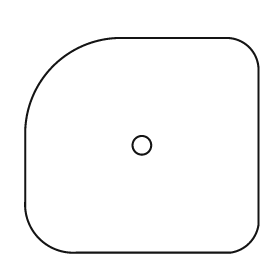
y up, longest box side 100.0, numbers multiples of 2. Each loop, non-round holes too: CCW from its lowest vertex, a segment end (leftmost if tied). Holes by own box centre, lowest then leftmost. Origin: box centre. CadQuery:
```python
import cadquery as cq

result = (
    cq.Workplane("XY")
    .moveTo(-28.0, -46.0)
    .lineTo(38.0, -46.0)
    .threePointArc((46.0, -42.0), (50.0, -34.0))
    .lineTo(50.0, 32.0)
    .threePointArc((46.0, 42.0), (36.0, 46.0))
    .lineTo(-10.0, 46.0)
    .threePointArc((-38.0, 34.0), (-50.0, 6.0))
    .lineTo(-50.0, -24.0)
    .threePointArc((-44.0, -40.0), (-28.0, -46.0))
    .close()
    .moveTo(0.0, 0.0)
    .circle(4.0)
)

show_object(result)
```